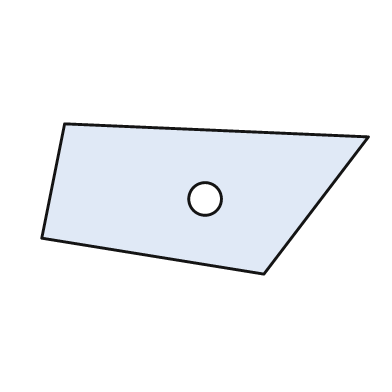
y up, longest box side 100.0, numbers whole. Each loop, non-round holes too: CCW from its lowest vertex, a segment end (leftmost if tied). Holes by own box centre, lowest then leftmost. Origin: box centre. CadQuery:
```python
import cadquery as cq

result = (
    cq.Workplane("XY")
    .moveTo(18.0, -23.0)
    .lineTo(50.0, 19.0)
    .lineTo(-43.0, 23.0)
    .lineTo(-50.0, -12.0)
    .close()
    .moveTo(0.0, 0.0)
    .circle(5.0)
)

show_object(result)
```